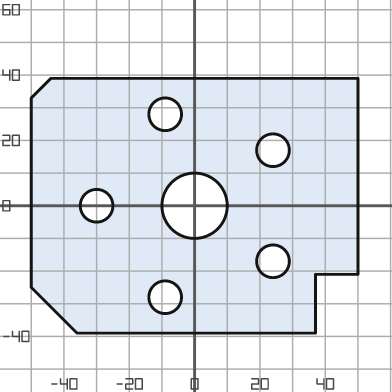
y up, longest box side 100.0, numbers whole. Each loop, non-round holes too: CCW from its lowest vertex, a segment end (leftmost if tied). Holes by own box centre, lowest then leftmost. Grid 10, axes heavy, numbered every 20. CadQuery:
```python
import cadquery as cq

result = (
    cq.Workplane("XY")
    .moveTo(-36.0, -39.0)
    .lineTo(37.0, -39.0)
    .lineTo(37.0, -21.0)
    .lineTo(50.0, -21.0)
    .lineTo(50.0, 39.0)
    .lineTo(-44.0, 39.0)
    .lineTo(-50.0, 33.0)
    .lineTo(-50.0, -25.0)
    .close()
    .moveTo(-9.0, -28.0)
    .circle(5.0)
    .moveTo(24.0, -17.0)
    .circle(5.0)
    .moveTo(-30.0, 0.0)
    .circle(5.0)
    .moveTo(0.0, 0.0)
    .circle(10.0)
    .moveTo(24.0, 17.0)
    .circle(5.0)
    .moveTo(-9.0, 28.0)
    .circle(5.0)
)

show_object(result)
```